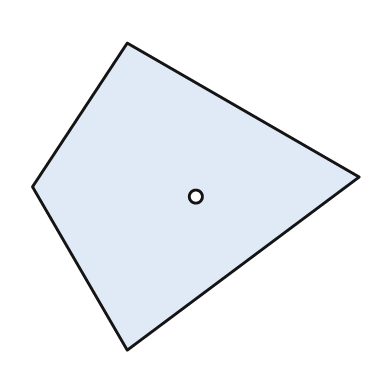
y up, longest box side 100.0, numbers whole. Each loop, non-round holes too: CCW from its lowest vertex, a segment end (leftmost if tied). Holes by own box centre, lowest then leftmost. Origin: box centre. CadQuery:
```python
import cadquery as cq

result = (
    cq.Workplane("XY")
    .moveTo(-21.0, -47.0)
    .lineTo(50.0, 6.0)
    .lineTo(-21.0, 47.0)
    .lineTo(-50.0, 3.0)
    .close()
    .moveTo(0.0, 0.0)
    .circle(2.0)
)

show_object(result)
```